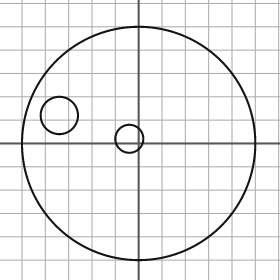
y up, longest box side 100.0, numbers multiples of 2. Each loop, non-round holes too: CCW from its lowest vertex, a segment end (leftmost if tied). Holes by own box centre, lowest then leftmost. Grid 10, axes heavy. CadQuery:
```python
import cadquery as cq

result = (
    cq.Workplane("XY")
    .moveTo(0.0, 0.0)
    .circle(50.0)
    .moveTo(-4.0, 2.0)
    .circle(6.0)
    .moveTo(-34.0, 12.0)
    .circle(8.0)
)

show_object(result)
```